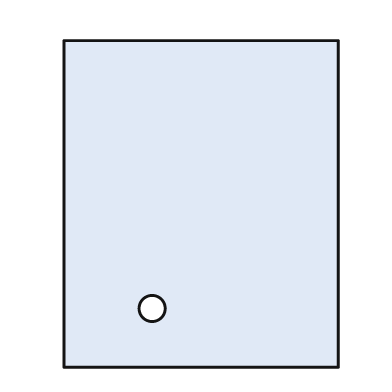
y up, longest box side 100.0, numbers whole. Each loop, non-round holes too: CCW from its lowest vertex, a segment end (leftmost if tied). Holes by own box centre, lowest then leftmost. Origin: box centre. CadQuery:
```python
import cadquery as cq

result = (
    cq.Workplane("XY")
    .moveTo(-42.0, -50.0)
    .lineTo(42.0, -50.0)
    .lineTo(42.0, 50.0)
    .lineTo(-42.0, 50.0)
    .close()
    .moveTo(-15.0, -32.0)
    .circle(4.0)
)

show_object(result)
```